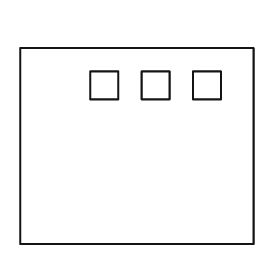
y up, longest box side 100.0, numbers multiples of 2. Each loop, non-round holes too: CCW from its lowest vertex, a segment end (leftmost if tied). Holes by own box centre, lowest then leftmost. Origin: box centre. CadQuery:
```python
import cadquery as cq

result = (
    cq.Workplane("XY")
    .moveTo(-50.0, -42.0)
    .lineTo(50.0, -42.0)
    .lineTo(50.0, 42.0)
    .lineTo(-50.0, 42.0)
    .close()
    .moveTo(-20.0, 20.0)
    .lineTo(-8.0, 20.0)
    .lineTo(-8.0, 32.0)
    .lineTo(-20.0, 32.0)
    .close()
    .moveTo(2.0, 20.0)
    .lineTo(14.0, 20.0)
    .lineTo(14.0, 32.0)
    .lineTo(2.0, 32.0)
    .close()
    .moveTo(24.0, 20.0)
    .lineTo(36.0, 20.0)
    .lineTo(36.0, 32.0)
    .lineTo(24.0, 32.0)
    .close()
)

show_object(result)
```